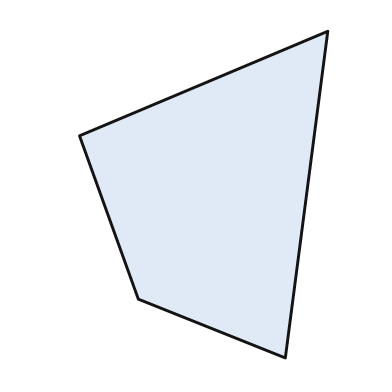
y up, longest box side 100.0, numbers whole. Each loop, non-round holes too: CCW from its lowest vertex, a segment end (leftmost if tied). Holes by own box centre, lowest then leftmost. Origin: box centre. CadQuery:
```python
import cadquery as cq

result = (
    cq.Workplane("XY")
    .moveTo(25.0, -50.0)
    .lineTo(38.0, 50.0)
    .lineTo(-38.0, 18.0)
    .lineTo(-20.0, -32.0)
    .close()
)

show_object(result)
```